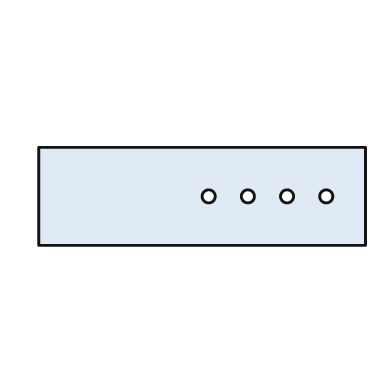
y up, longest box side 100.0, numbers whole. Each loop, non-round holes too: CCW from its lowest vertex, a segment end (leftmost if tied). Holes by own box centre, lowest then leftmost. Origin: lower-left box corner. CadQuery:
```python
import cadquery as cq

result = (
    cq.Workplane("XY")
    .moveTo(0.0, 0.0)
    .lineTo(100.0, 0.0)
    .lineTo(100.0, 30.0)
    .lineTo(0.0, 30.0)
    .close()
    .moveTo(52.0, 15.0)
    .circle(2.0)
    .moveTo(64.0, 15.0)
    .circle(2.0)
    .moveTo(76.0, 15.0)
    .circle(2.0)
    .moveTo(88.0, 15.0)
    .circle(2.0)
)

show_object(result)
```